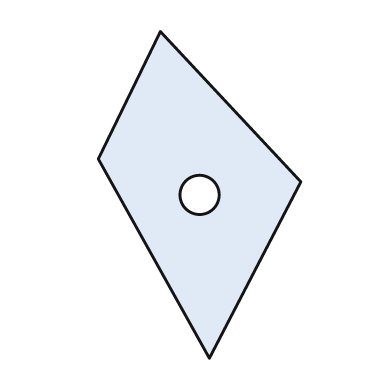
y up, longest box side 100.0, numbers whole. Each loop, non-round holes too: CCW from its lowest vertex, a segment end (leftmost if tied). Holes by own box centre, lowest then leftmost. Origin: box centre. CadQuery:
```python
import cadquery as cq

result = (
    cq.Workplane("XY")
    .moveTo(3.0, -50.0)
    .lineTo(31.0, 4.0)
    .lineTo(-12.0, 50.0)
    .lineTo(-31.0, 11.0)
    .close()
    .moveTo(0.0, 0.0)
    .circle(6.0)
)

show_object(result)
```